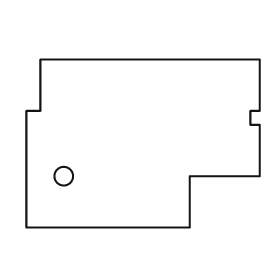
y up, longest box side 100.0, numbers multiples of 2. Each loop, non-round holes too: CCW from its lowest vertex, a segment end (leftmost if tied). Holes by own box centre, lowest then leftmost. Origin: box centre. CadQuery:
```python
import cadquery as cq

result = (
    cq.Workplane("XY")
    .moveTo(-50.0, -36.0)
    .lineTo(20.0, -36.0)
    .lineTo(20.0, -14.0)
    .lineTo(50.0, -14.0)
    .lineTo(50.0, 8.0)
    .lineTo(46.0, 8.0)
    .lineTo(46.0, 14.0)
    .lineTo(50.0, 14.0)
    .lineTo(50.0, 36.0)
    .lineTo(-44.0, 36.0)
    .lineTo(-44.0, 14.0)
    .lineTo(-50.0, 14.0)
    .close()
    .moveTo(-34.0, -14.0)
    .circle(4.0)
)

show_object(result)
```